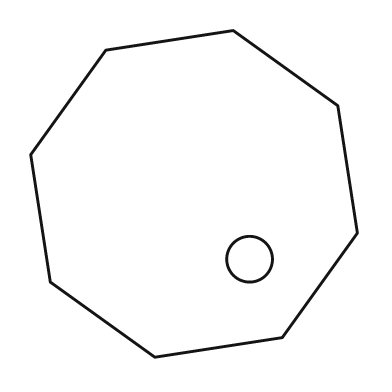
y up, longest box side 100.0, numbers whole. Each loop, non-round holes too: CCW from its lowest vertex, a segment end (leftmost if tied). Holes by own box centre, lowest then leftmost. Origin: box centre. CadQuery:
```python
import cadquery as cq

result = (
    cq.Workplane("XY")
    .moveTo(-12.0, -50.0)
    .lineTo(27.0, -44.0)
    .lineTo(50.0, -12.0)
    .lineTo(44.0, 27.0)
    .lineTo(12.0, 50.0)
    .lineTo(-27.0, 44.0)
    .lineTo(-50.0, 12.0)
    .lineTo(-44.0, -27.0)
    .close()
    .moveTo(17.0, -20.0)
    .circle(7.0)
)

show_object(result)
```